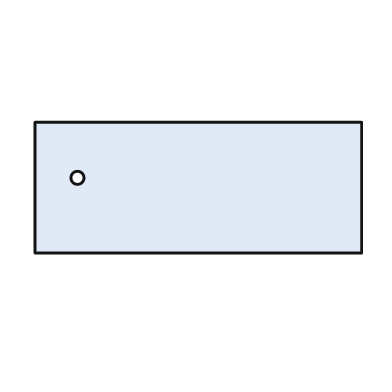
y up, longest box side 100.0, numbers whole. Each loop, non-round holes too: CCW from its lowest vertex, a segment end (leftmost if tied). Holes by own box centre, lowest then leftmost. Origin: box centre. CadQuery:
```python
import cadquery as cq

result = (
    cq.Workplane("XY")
    .moveTo(-50.0, -20.0)
    .lineTo(50.0, -20.0)
    .lineTo(50.0, 20.0)
    .lineTo(-50.0, 20.0)
    .close()
    .moveTo(-37.0, 3.0)
    .circle(2.0)
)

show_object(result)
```